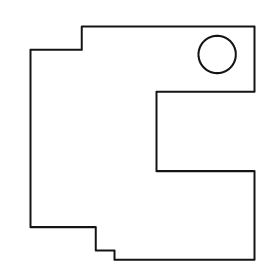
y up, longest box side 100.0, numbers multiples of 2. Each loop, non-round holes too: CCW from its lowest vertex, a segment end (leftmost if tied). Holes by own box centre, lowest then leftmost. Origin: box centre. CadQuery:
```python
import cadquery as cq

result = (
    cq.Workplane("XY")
    .moveTo(-12.0, -50.0)
    .lineTo(48.0, -50.0)
    .lineTo(48.0, -12.0)
    .lineTo(6.0, -12.0)
    .lineTo(6.0, 22.0)
    .lineTo(48.0, 22.0)
    .lineTo(48.0, 50.0)
    .lineTo(-26.0, 50.0)
    .lineTo(-26.0, 40.0)
    .lineTo(-48.0, 40.0)
    .lineTo(-48.0, -36.0)
    .lineTo(-20.0, -36.0)
    .lineTo(-20.0, -46.0)
    .lineTo(-12.0, -46.0)
    .close()
    .moveTo(32.0, 38.0)
    .circle(8.0)
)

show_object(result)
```